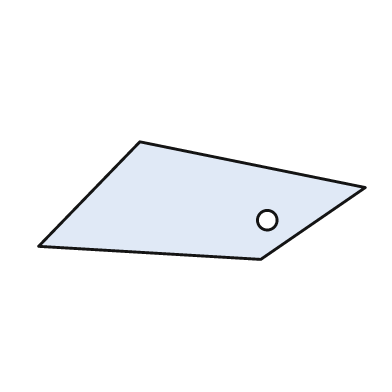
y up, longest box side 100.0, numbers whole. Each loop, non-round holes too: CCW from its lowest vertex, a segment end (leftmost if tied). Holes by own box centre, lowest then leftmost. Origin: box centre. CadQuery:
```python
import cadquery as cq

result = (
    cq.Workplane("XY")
    .moveTo(18.0, -18.0)
    .lineTo(50.0, 4.0)
    .lineTo(-19.0, 18.0)
    .lineTo(-50.0, -14.0)
    .close()
    .moveTo(20.0, -6.0)
    .circle(3.0)
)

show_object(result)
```